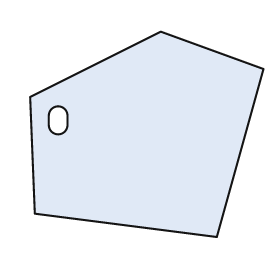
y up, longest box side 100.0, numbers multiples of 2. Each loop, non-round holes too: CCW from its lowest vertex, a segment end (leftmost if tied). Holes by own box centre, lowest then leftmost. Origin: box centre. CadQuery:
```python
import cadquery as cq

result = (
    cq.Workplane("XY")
    .moveTo(30.0, -44.0)
    .lineTo(50.0, 28.0)
    .lineTo(6.0, 44.0)
    .lineTo(-50.0, 16.0)
    .lineTo(-48.0, -34.0)
    .close()
    .moveTo(-42.0, 4.0)
    .threePointArc((-38.0, 0.0), (-34.0, 4.0))
    .lineTo(-34.0, 8.0)
    .threePointArc((-38.0, 12.0), (-42.0, 8.0))
    .close()
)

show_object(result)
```